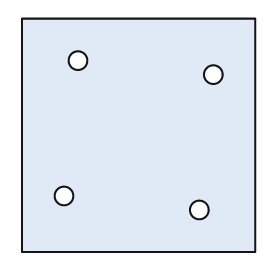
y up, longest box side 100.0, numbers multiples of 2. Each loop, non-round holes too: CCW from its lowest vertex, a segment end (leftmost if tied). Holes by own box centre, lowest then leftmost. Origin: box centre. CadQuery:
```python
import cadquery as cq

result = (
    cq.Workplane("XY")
    .moveTo(-50.0, -50.0)
    .lineTo(50.0, -50.0)
    .lineTo(50.0, 50.0)
    .lineTo(-50.0, 50.0)
    .close()
    .moveTo(26.0, -32.0)
    .circle(4.0)
    .moveTo(-32.0, -26.0)
    .circle(4.0)
    .moveTo(32.0, 26.0)
    .circle(4.0)
    .moveTo(-26.0, 32.0)
    .circle(4.0)
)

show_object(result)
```